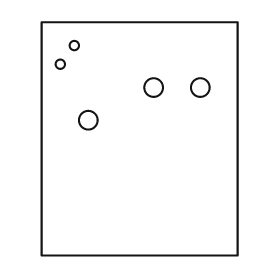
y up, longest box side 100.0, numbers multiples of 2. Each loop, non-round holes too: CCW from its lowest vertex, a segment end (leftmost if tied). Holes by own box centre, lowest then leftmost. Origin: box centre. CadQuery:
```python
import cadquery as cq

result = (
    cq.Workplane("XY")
    .moveTo(-42.0, -50.0)
    .lineTo(42.0, -50.0)
    .lineTo(42.0, 50.0)
    .lineTo(-42.0, 50.0)
    .close()
    .moveTo(-22.0, 8.0)
    .circle(4.0)
    .moveTo(6.0, 22.0)
    .circle(4.0)
    .moveTo(26.0, 22.0)
    .circle(4.0)
    .moveTo(-34.0, 32.0)
    .circle(2.0)
    .moveTo(-28.0, 40.0)
    .circle(2.0)
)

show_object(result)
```